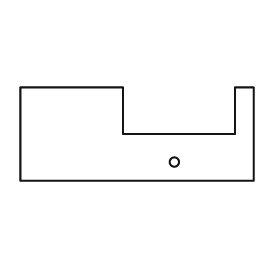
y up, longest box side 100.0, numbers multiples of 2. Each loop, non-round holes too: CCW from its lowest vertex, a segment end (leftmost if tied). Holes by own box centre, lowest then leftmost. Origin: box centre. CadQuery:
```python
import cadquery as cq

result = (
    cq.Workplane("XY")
    .moveTo(-50.0, -20.0)
    .lineTo(50.0, -20.0)
    .lineTo(50.0, 20.0)
    .lineTo(42.0, 20.0)
    .lineTo(42.0, 0.0)
    .lineTo(-6.0, 0.0)
    .lineTo(-6.0, 20.0)
    .lineTo(-50.0, 20.0)
    .close()
    .moveTo(16.0, -12.0)
    .circle(2.0)
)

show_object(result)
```